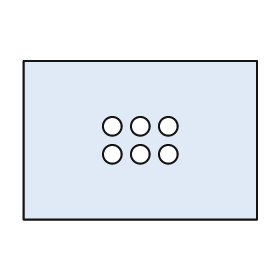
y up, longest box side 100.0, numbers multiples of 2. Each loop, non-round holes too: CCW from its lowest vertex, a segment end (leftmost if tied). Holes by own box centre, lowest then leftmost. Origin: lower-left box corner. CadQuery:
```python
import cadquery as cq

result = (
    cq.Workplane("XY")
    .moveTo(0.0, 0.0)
    .lineTo(100.0, 0.0)
    .lineTo(100.0, 68.0)
    .lineTo(0.0, 68.0)
    .close()
    .moveTo(38.0, 28.0)
    .circle(4.0)
    .moveTo(50.0, 28.0)
    .circle(4.0)
    .moveTo(62.0, 28.0)
    .circle(4.0)
    .moveTo(38.0, 40.0)
    .circle(4.0)
    .moveTo(50.0, 40.0)
    .circle(4.0)
    .moveTo(62.0, 40.0)
    .circle(4.0)
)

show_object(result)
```